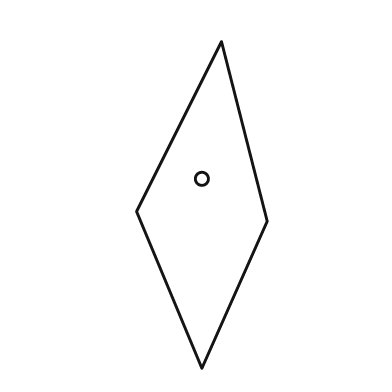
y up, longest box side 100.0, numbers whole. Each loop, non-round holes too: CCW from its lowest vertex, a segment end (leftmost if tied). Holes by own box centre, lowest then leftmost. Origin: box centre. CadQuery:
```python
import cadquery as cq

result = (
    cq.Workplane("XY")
    .moveTo(0.0, -50.0)
    .lineTo(20.0, -5.0)
    .lineTo(6.0, 50.0)
    .lineTo(-20.0, -2.0)
    .close()
    .moveTo(0.0, 8.0)
    .circle(2.0)
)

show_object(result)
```